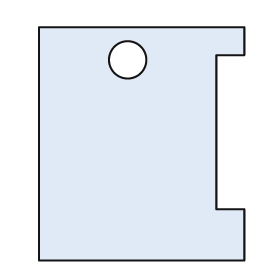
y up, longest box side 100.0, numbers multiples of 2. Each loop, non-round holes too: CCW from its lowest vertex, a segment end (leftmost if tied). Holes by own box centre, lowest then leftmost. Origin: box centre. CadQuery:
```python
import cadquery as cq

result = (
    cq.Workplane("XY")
    .moveTo(-44.0, -50.0)
    .lineTo(44.0, -50.0)
    .lineTo(44.0, -28.0)
    .lineTo(32.0, -28.0)
    .lineTo(32.0, 38.0)
    .lineTo(44.0, 38.0)
    .lineTo(44.0, 50.0)
    .lineTo(-44.0, 50.0)
    .close()
    .moveTo(-6.0, 36.0)
    .circle(8.0)
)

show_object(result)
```